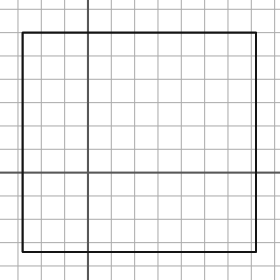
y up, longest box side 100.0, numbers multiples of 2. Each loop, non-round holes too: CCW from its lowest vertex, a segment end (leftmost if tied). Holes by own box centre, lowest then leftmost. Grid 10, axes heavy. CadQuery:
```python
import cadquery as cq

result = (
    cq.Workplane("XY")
    .moveTo(-28.0, -34.0)
    .lineTo(72.0, -34.0)
    .lineTo(72.0, 60.0)
    .lineTo(-28.0, 60.0)
    .close()
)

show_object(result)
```